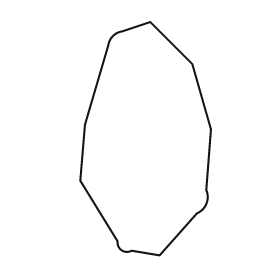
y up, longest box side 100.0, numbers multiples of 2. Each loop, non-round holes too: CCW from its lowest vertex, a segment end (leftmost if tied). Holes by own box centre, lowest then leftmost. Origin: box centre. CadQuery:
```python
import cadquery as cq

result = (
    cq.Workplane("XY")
    .moveTo(6.0, -50.0)
    .lineTo(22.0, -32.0)
    .threePointArc((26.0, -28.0), (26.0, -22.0))
    .lineTo(28.0, 4.0)
    .lineTo(20.0, 32.0)
    .lineTo(2.0, 50.0)
    .lineTo(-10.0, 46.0)
    .threePointArc((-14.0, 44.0), (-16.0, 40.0))
    .lineTo(-26.0, 6.0)
    .lineTo(-28.0, -18.0)
    .lineTo(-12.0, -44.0)
    .threePointArc((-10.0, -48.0), (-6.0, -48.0))
    .close()
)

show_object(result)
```